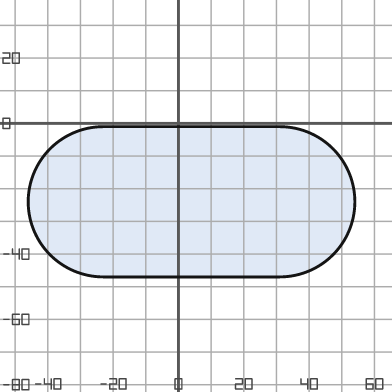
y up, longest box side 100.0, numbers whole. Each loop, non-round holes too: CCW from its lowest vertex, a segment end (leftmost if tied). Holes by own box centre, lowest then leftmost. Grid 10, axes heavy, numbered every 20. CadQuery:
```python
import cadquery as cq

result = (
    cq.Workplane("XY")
    .moveTo(-23.0, -47.0)
    .lineTo(31.0, -47.0)
    .threePointArc((54.0, -24.0), (31.0, -1.0))
    .lineTo(-23.0, -1.0)
    .threePointArc((-46.0, -24.0), (-23.0, -47.0))
    .close()
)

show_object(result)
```